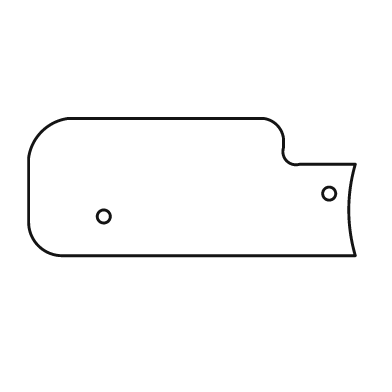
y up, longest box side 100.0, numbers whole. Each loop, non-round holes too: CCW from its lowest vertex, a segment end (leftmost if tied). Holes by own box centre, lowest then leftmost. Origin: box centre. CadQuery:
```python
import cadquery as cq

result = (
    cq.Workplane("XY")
    .moveTo(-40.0, -21.0)
    .lineTo(50.0, -21.0)
    .threePointArc((48.0, -7.0), (50.0, 7.0))
    .lineTo(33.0, 7.0)
    .threePointArc((29.0, 8.0), (28.0, 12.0))
    .lineTo(28.0, 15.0)
    .threePointArc((26.0, 19.0), (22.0, 21.0))
    .lineTo(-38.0, 21.0)
    .threePointArc((-46.0, 17.0), (-50.0, 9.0))
    .lineTo(-50.0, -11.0)
    .threePointArc((-47.0, -18.0), (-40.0, -21.0))
    .close()
    .moveTo(-27.0, -9.0)
    .circle(2.0)
    .moveTo(42.0, -2.0)
    .circle(2.0)
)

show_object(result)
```